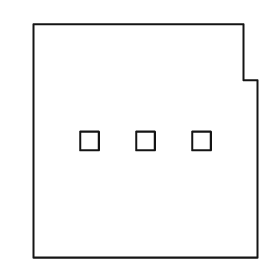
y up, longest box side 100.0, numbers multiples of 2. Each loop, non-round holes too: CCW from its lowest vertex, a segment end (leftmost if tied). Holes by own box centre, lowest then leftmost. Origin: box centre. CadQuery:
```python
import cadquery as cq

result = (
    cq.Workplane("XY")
    .moveTo(-48.0, -50.0)
    .lineTo(48.0, -50.0)
    .lineTo(48.0, 26.0)
    .lineTo(42.0, 26.0)
    .lineTo(42.0, 50.0)
    .lineTo(-48.0, 50.0)
    .close()
    .moveTo(-28.0, -4.0)
    .lineTo(-20.0, -4.0)
    .lineTo(-20.0, 4.0)
    .lineTo(-28.0, 4.0)
    .close()
    .moveTo(-4.0, -4.0)
    .lineTo(4.0, -4.0)
    .lineTo(4.0, 4.0)
    .lineTo(-4.0, 4.0)
    .close()
    .moveTo(20.0, -4.0)
    .lineTo(28.0, -4.0)
    .lineTo(28.0, 4.0)
    .lineTo(20.0, 4.0)
    .close()
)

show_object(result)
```